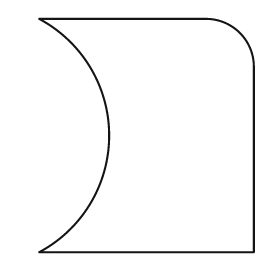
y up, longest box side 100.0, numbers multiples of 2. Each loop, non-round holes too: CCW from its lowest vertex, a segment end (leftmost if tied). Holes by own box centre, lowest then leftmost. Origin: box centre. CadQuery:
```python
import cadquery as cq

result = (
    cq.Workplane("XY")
    .moveTo(-46.0, -50.0)
    .lineTo(46.0, -50.0)
    .lineTo(46.0, 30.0)
    .threePointArc((40.0, 44.0), (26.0, 50.0))
    .lineTo(-46.0, 50.0)
    .threePointArc((-16.0, 0.0), (-46.0, -50.0))
    .close()
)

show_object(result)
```